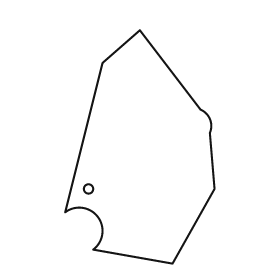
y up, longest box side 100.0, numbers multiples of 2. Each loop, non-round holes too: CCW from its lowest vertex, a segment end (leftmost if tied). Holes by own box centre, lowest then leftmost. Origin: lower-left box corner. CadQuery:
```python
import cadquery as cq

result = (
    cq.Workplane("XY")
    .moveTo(46.0, 0.0)
    .lineTo(64.0, 32.0)
    .lineTo(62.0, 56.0)
    .threePointArc((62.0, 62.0), (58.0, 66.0))
    .lineTo(32.0, 100.0)
    .lineTo(16.0, 86.0)
    .lineTo(0.0, 22.0)
    .threePointArc((14.0, 20.0), (12.0, 6.0))
    .close()
    .moveTo(10.0, 32.0)
    .circle(2.0)
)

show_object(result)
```